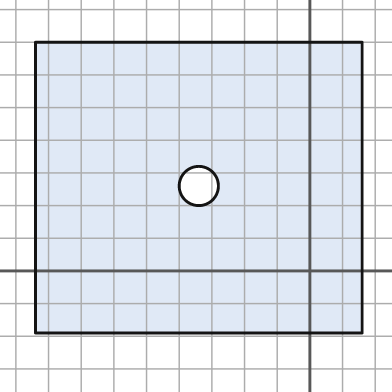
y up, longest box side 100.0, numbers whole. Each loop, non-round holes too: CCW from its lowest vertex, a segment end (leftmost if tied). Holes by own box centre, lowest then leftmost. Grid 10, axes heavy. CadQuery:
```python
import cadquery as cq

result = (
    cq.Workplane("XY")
    .moveTo(-84.0, -19.0)
    .lineTo(16.0, -19.0)
    .lineTo(16.0, 70.0)
    .lineTo(-84.0, 70.0)
    .close()
    .moveTo(-34.0, 26.0)
    .circle(6.0)
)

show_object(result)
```